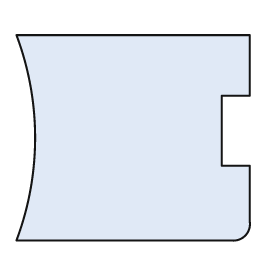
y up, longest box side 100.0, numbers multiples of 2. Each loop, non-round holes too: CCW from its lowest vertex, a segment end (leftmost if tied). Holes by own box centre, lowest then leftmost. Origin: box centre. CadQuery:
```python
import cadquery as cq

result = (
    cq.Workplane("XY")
    .moveTo(-50.0, -44.0)
    .lineTo(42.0, -44.0)
    .threePointArc((48.0, -42.0), (50.0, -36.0))
    .lineTo(50.0, -12.0)
    .lineTo(38.0, -12.0)
    .lineTo(38.0, 18.0)
    .lineTo(50.0, 18.0)
    .lineTo(50.0, 44.0)
    .lineTo(-50.0, 44.0)
    .threePointArc((-42.0, 0.0), (-50.0, -44.0))
    .close()
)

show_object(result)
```